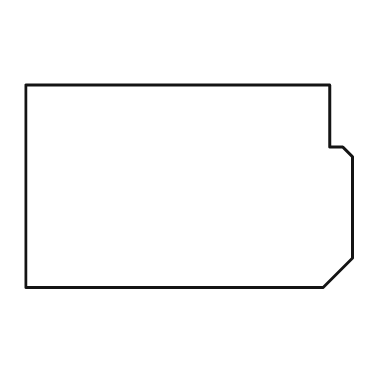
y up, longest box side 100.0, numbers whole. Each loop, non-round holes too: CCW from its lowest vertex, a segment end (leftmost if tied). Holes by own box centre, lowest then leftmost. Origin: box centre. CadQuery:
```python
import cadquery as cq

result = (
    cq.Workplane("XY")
    .moveTo(-50.0, -31.0)
    .lineTo(41.0, -31.0)
    .lineTo(50.0, -22.0)
    .lineTo(50.0, 9.0)
    .lineTo(47.0, 12.0)
    .lineTo(43.0, 12.0)
    .lineTo(43.0, 31.0)
    .lineTo(-50.0, 31.0)
    .close()
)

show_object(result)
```